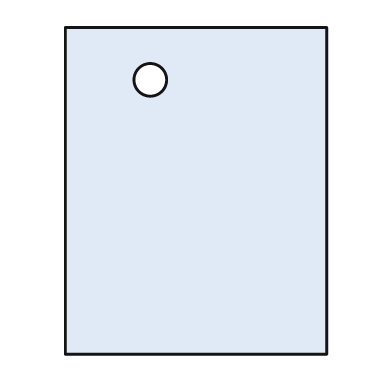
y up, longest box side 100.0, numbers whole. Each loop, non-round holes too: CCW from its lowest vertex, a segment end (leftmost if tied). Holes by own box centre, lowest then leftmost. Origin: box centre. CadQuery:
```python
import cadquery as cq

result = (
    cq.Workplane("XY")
    .moveTo(-40.0, -50.0)
    .lineTo(40.0, -50.0)
    .lineTo(40.0, 50.0)
    .lineTo(-40.0, 50.0)
    .close()
    .moveTo(-14.0, 34.0)
    .circle(5.0)
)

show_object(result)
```